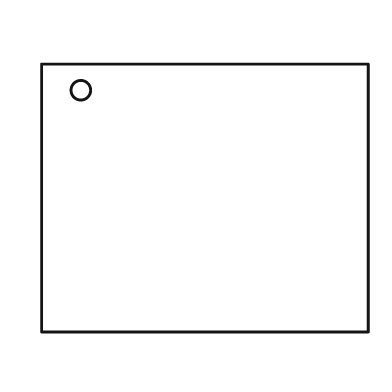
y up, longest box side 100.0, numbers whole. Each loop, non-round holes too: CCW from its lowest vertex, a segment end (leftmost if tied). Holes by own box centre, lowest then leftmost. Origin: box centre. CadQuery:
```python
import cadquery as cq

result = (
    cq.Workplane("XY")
    .moveTo(-50.0, -41.0)
    .lineTo(50.0, -41.0)
    .lineTo(50.0, 41.0)
    .lineTo(-50.0, 41.0)
    .close()
    .moveTo(-38.0, 33.0)
    .circle(3.0)
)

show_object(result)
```